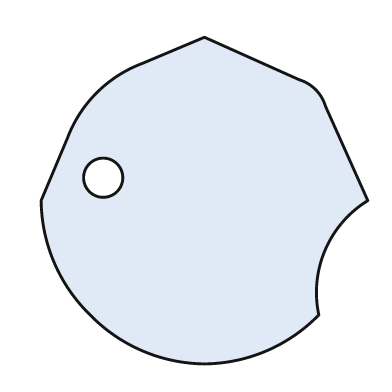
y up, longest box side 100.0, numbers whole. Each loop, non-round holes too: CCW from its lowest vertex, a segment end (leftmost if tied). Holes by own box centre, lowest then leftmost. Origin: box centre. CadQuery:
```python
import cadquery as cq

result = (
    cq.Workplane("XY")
    .moveTo(0.0, -50.0)
    .threePointArc((19.0, -46.0), (35.0, -35.0))
    .threePointArc((37.0, -15.0), (50.0, 0.0))
    .lineTo(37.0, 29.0)
    .threePointArc((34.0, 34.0), (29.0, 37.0))
    .lineTo(0.0, 50.0)
    .lineTo(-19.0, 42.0)
    .threePointArc((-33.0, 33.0), (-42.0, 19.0))
    .lineTo(-50.0, 0.0)
    .threePointArc((-46.0, -19.0), (-35.0, -35.0))
    .threePointArc((-19.0, -46.0), (0.0, -50.0))
    .close()
    .moveTo(-31.0, 7.0)
    .circle(6.0)
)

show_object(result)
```